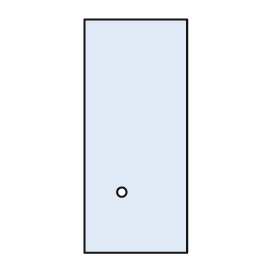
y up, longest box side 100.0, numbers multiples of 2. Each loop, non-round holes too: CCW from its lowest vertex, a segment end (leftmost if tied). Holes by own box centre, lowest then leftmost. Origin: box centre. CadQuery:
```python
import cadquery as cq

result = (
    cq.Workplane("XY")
    .moveTo(-22.0, -50.0)
    .lineTo(22.0, -50.0)
    .lineTo(22.0, 50.0)
    .lineTo(-22.0, 50.0)
    .close()
    .moveTo(-6.0, -24.0)
    .circle(2.0)
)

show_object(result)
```